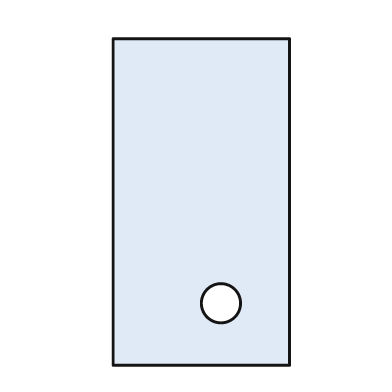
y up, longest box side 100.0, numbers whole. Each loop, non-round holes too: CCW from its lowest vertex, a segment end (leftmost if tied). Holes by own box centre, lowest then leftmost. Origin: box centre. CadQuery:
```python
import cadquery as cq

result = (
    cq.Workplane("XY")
    .moveTo(-27.0, -50.0)
    .lineTo(27.0, -50.0)
    .lineTo(27.0, 50.0)
    .lineTo(-27.0, 50.0)
    .close()
    .moveTo(6.0, -31.0)
    .circle(6.0)
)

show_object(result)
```